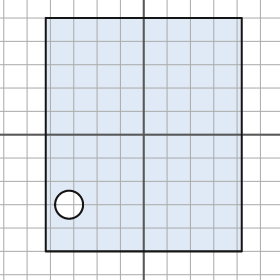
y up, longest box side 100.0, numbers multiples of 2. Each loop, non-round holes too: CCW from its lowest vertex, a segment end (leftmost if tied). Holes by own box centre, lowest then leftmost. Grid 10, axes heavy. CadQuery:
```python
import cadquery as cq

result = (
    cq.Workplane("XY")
    .moveTo(-42.0, -50.0)
    .lineTo(42.0, -50.0)
    .lineTo(42.0, 50.0)
    .lineTo(-42.0, 50.0)
    .close()
    .moveTo(-32.0, -30.0)
    .circle(6.0)
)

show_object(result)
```